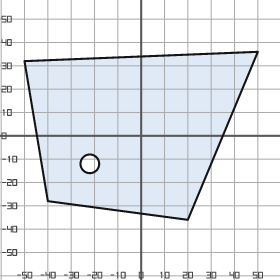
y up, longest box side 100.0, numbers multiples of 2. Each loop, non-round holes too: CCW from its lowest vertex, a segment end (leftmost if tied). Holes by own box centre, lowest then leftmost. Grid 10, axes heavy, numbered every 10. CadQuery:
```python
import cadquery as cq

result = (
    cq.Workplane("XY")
    .moveTo(20.0, -36.0)
    .lineTo(50.0, 36.0)
    .lineTo(-50.0, 32.0)
    .lineTo(-40.0, -28.0)
    .close()
    .moveTo(-22.0, -12.0)
    .circle(4.0)
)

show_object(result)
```